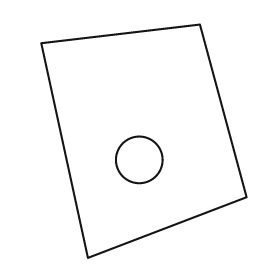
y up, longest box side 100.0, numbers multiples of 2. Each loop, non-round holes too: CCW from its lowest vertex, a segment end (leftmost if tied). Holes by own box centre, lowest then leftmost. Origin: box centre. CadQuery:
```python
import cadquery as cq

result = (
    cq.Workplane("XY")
    .moveTo(-24.0, -50.0)
    .lineTo(44.0, -24.0)
    .lineTo(24.0, 50.0)
    .lineTo(-44.0, 42.0)
    .close()
    .moveTo(-2.0, -8.0)
    .circle(10.0)
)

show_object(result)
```